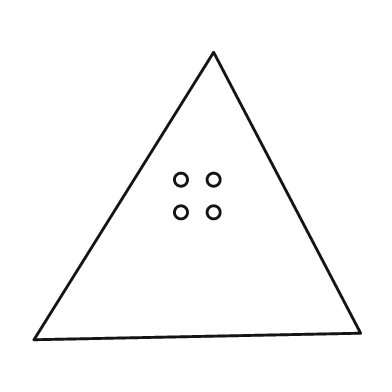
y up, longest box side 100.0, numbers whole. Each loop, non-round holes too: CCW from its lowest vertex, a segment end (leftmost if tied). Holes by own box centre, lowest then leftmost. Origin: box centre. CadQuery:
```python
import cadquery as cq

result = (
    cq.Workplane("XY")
    .moveTo(-50.0, -44.0)
    .lineTo(50.0, -42.0)
    .lineTo(5.0, 44.0)
    .close()
    .moveTo(-5.0, -5.0)
    .circle(2.0)
    .moveTo(5.0, -5.0)
    .circle(2.0)
    .moveTo(-5.0, 5.0)
    .circle(2.0)
    .moveTo(5.0, 5.0)
    .circle(2.0)
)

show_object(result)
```